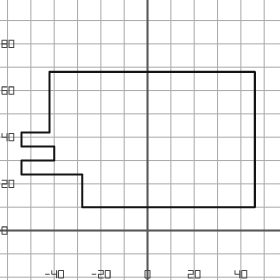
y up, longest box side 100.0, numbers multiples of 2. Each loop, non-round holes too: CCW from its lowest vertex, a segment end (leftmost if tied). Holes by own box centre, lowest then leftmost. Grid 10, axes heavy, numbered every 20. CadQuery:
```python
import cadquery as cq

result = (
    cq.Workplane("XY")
    .moveTo(-28.0, 10.0)
    .lineTo(46.0, 10.0)
    .lineTo(46.0, 68.0)
    .lineTo(-42.0, 68.0)
    .lineTo(-42.0, 42.0)
    .lineTo(-54.0, 42.0)
    .lineTo(-54.0, 36.0)
    .lineTo(-40.0, 36.0)
    .lineTo(-40.0, 30.0)
    .lineTo(-54.0, 30.0)
    .lineTo(-54.0, 24.0)
    .lineTo(-28.0, 24.0)
    .close()
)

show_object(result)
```